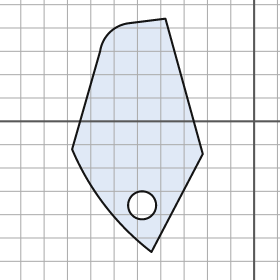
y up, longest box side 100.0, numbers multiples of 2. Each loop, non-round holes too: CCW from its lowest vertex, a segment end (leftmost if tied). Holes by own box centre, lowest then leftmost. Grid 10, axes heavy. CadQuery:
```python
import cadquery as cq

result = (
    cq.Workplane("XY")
    .moveTo(-44.0, -56.0)
    .lineTo(-22.0, -14.0)
    .lineTo(-38.0, 44.0)
    .lineTo(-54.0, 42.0)
    .threePointArc((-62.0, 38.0), (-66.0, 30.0))
    .lineTo(-78.0, -12.0)
    .threePointArc((-64.0, -36.0), (-44.0, -56.0))
    .close()
    .moveTo(-48.0, -36.0)
    .circle(6.0)
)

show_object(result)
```